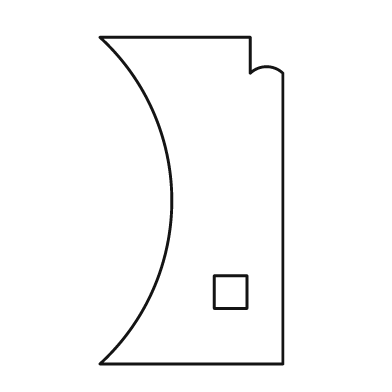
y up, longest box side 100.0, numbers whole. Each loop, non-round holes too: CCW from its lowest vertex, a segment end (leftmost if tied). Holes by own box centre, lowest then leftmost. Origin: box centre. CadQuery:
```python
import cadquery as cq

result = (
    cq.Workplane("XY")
    .moveTo(-28.0, -50.0)
    .lineTo(28.0, -50.0)
    .lineTo(28.0, 39.0)
    .threePointArc((23.0, 41.0), (18.0, 39.0))
    .lineTo(18.0, 50.0)
    .lineTo(-28.0, 50.0)
    .threePointArc((-6.0, 0.0), (-28.0, -50.0))
    .close()
    .moveTo(7.0, -33.0)
    .lineTo(17.0, -33.0)
    .lineTo(17.0, -23.0)
    .lineTo(7.0, -23.0)
    .close()
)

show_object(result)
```